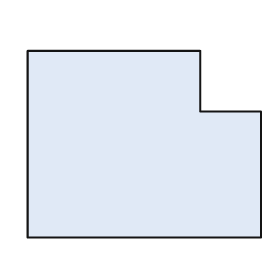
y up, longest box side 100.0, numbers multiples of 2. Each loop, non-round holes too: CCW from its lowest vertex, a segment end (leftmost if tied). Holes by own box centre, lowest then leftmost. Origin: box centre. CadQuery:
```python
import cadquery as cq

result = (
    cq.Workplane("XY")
    .moveTo(-50.0, -40.0)
    .lineTo(50.0, -40.0)
    .lineTo(50.0, 14.0)
    .lineTo(24.0, 14.0)
    .lineTo(24.0, 40.0)
    .lineTo(-50.0, 40.0)
    .close()
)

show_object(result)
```